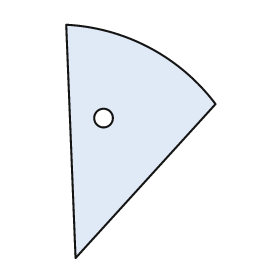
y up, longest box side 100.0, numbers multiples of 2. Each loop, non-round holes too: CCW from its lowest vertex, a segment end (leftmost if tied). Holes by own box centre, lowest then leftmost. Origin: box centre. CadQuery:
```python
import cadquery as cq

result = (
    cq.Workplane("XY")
    .moveTo(-28.0, -50.0)
    .lineTo(32.0, 16.0)
    .threePointArc((4.0, 40.0), (-32.0, 50.0))
    .close()
    .moveTo(-16.0, 10.0)
    .circle(4.0)
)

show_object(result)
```